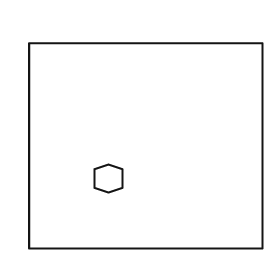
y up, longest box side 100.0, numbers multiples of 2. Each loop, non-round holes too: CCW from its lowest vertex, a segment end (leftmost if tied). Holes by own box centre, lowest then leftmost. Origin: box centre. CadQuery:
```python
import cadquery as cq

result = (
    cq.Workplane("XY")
    .moveTo(-50.0, -44.0)
    .lineTo(50.0, -44.0)
    .lineTo(50.0, 44.0)
    .lineTo(-50.0, 44.0)
    .close()
    .moveTo(-16.0, -20.0)
    .lineTo(-10.0, -18.0)
    .lineTo(-10.0, -10.0)
    .lineTo(-16.0, -8.0)
    .lineTo(-22.0, -10.0)
    .lineTo(-22.0, -18.0)
    .close()
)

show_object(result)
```